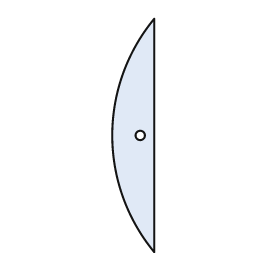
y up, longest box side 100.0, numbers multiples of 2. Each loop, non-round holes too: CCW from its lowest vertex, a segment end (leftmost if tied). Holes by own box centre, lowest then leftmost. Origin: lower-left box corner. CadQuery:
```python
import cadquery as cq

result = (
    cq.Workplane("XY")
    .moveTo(18.0, 0.0)
    .lineTo(18.0, 100.0)
    .threePointArc((0.0, 50.0), (18.0, 0.0))
    .close()
    .moveTo(12.0, 50.0)
    .circle(2.0)
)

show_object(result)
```